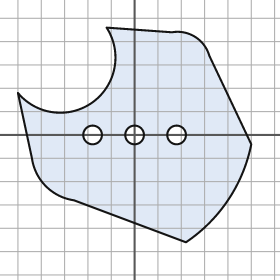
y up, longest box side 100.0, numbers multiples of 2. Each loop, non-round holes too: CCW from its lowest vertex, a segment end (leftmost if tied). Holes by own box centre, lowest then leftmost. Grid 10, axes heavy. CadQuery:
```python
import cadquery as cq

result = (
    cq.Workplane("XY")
    .moveTo(22.0, -46.0)
    .threePointArc((40.0, -28.0), (50.0, -4.0))
    .lineTo(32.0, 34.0)
    .threePointArc((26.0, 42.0), (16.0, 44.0))
    .lineTo(-12.0, 46.0)
    .threePointArc((-18.0, 14.0), (-50.0, 18.0))
    .lineTo(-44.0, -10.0)
    .threePointArc((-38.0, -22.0), (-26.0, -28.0))
    .close()
    .moveTo(-18.0, 0.0)
    .circle(4.0)
    .moveTo(0.0, 0.0)
    .circle(4.0)
    .moveTo(18.0, 0.0)
    .circle(4.0)
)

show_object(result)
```